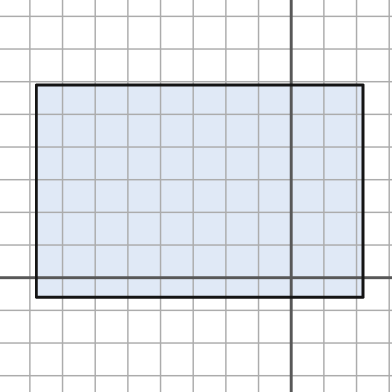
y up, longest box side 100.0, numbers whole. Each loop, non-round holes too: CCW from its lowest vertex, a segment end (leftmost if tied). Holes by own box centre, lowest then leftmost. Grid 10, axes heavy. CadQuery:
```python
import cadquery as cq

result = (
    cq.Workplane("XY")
    .moveTo(-78.0, -6.0)
    .lineTo(22.0, -6.0)
    .lineTo(22.0, 59.0)
    .lineTo(-78.0, 59.0)
    .close()
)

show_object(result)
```